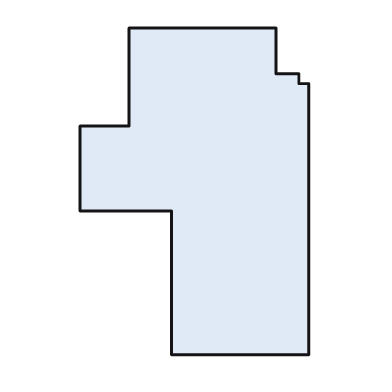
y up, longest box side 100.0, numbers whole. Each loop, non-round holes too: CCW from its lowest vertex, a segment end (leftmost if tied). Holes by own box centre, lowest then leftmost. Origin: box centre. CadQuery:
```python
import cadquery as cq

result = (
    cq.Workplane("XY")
    .moveTo(-7.0, -50.0)
    .lineTo(35.0, -50.0)
    .lineTo(35.0, 33.0)
    .lineTo(32.0, 33.0)
    .lineTo(32.0, 36.0)
    .lineTo(25.0, 36.0)
    .lineTo(25.0, 50.0)
    .lineTo(-20.0, 50.0)
    .lineTo(-20.0, 20.0)
    .lineTo(-35.0, 20.0)
    .lineTo(-35.0, -6.0)
    .lineTo(-7.0, -6.0)
    .close()
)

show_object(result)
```